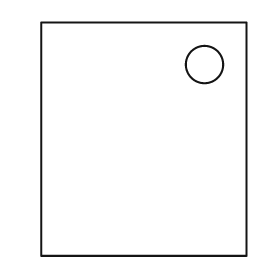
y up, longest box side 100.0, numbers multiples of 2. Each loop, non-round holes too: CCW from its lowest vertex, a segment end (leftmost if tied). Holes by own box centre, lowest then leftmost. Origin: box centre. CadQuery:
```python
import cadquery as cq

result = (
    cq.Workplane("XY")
    .moveTo(-44.0, -50.0)
    .lineTo(44.0, -50.0)
    .lineTo(44.0, 50.0)
    .lineTo(-44.0, 50.0)
    .close()
    .moveTo(26.0, 32.0)
    .circle(8.0)
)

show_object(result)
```